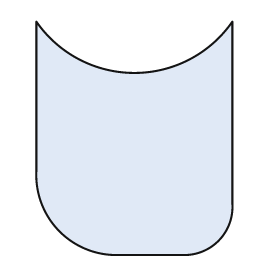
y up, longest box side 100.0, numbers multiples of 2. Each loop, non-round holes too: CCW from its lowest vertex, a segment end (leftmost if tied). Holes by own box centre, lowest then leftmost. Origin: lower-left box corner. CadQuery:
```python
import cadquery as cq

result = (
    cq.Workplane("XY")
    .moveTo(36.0, 0.0)
    .lineTo(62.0, 0.0)
    .threePointArc((78.0, 6.0), (84.0, 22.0))
    .lineTo(84.0, 100.0)
    .threePointArc((42.0, 78.0), (0.0, 100.0))
    .lineTo(0.0, 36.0)
    .threePointArc((10.0, 10.0), (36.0, 0.0))
    .close()
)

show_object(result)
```